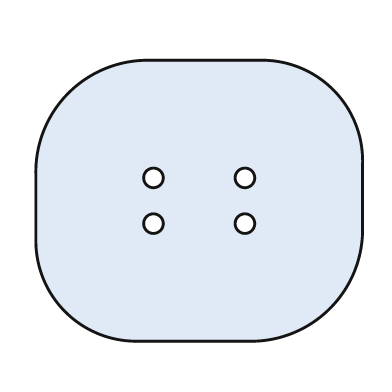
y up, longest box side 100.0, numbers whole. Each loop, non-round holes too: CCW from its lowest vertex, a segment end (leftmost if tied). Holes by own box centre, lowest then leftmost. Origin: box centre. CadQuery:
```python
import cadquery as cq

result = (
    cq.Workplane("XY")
    .moveTo(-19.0, -43.0)
    .lineTo(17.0, -43.0)
    .threePointArc((40.0, -33.0), (50.0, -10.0))
    .lineTo(50.0, 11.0)
    .threePointArc((41.0, 34.0), (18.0, 43.0))
    .lineTo(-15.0, 43.0)
    .threePointArc((-40.0, 33.0), (-50.0, 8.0))
    .lineTo(-50.0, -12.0)
    .threePointArc((-41.0, -34.0), (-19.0, -43.0))
    .close()
    .moveTo(-14.0, -7.0)
    .circle(3.0)
    .moveTo(14.0, -7.0)
    .circle(3.0)
    .moveTo(-14.0, 7.0)
    .circle(3.0)
    .moveTo(14.0, 7.0)
    .circle(3.0)
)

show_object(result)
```